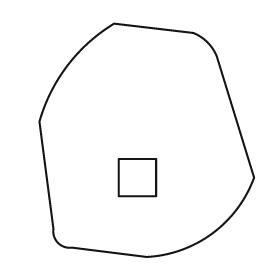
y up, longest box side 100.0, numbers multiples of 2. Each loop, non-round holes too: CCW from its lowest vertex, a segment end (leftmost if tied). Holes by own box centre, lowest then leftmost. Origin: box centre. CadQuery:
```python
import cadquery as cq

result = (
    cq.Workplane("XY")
    .moveTo(0.0, -50.0)
    .threePointArc((28.0, -40.0), (46.0, -16.0))
    .lineTo(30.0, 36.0)
    .threePointArc((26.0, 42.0), (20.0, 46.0))
    .lineTo(-14.0, 50.0)
    .threePointArc((-34.0, 32.0), (-46.0, 8.0))
    .lineTo(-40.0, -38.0)
    .threePointArc((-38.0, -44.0), (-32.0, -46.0))
    .close()
    .moveTo(-12.0, -24.0)
    .lineTo(4.0, -24.0)
    .lineTo(4.0, -8.0)
    .lineTo(-12.0, -8.0)
    .close()
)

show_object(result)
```